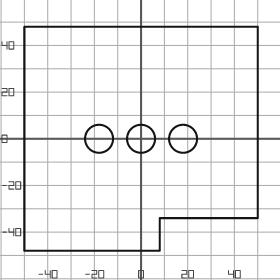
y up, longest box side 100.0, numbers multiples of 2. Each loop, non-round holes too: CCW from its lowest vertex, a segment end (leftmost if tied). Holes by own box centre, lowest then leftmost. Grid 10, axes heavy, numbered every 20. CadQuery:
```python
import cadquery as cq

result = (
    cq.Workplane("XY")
    .moveTo(-50.0, -48.0)
    .lineTo(8.0, -48.0)
    .lineTo(8.0, -34.0)
    .lineTo(50.0, -34.0)
    .lineTo(50.0, 48.0)
    .lineTo(-50.0, 48.0)
    .close()
    .moveTo(-18.0, 0.0)
    .circle(6.0)
    .moveTo(0.0, 0.0)
    .circle(6.0)
    .moveTo(18.0, 0.0)
    .circle(6.0)
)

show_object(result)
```